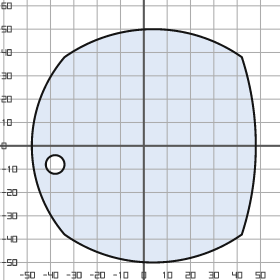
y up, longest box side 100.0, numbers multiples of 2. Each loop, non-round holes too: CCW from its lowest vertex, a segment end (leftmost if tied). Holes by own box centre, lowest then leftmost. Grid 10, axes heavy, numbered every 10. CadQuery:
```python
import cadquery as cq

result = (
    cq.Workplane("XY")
    .moveTo(-34.0, -38.0)
    .threePointArc((4.0, -50.0), (42.0, -38.0))
    .threePointArc((48.0, 0.0), (42.0, 38.0))
    .threePointArc((4.0, 50.0), (-34.0, 38.0))
    .threePointArc((-48.0, 0.0), (-34.0, -38.0))
    .close()
    .moveTo(-38.0, -8.0)
    .circle(4.0)
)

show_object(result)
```